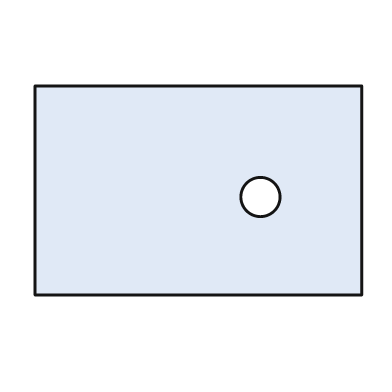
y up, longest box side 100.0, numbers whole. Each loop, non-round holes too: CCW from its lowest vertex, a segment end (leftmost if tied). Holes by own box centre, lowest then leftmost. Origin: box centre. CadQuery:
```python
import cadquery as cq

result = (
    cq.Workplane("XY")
    .moveTo(-50.0, -32.0)
    .lineTo(50.0, -32.0)
    .lineTo(50.0, 32.0)
    .lineTo(-50.0, 32.0)
    .close()
    .moveTo(19.0, -2.0)
    .circle(6.0)
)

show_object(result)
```